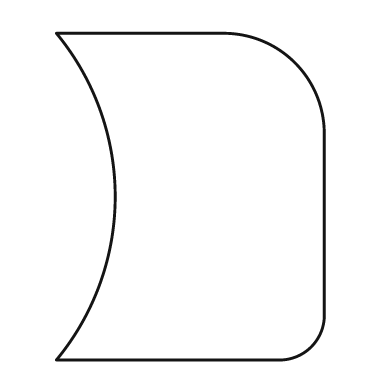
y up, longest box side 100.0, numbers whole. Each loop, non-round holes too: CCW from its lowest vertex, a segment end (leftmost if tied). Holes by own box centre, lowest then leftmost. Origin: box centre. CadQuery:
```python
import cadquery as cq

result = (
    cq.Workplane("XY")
    .moveTo(-41.0, -50.0)
    .lineTo(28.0, -50.0)
    .threePointArc((37.0, -46.0), (41.0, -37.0))
    .lineTo(41.0, 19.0)
    .threePointArc((32.0, 41.0), (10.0, 50.0))
    .lineTo(-41.0, 50.0)
    .threePointArc((-23.0, 0.0), (-41.0, -50.0))
    .close()
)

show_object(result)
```